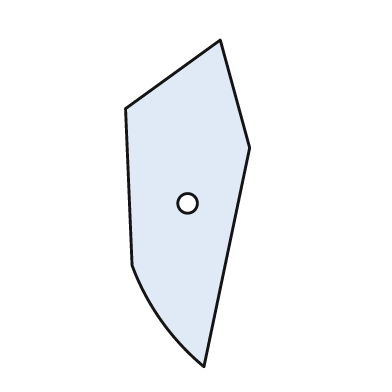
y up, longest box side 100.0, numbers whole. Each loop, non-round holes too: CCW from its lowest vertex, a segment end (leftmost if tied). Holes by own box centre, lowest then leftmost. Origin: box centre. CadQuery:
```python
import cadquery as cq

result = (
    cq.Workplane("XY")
    .moveTo(5.0, -50.0)
    .lineTo(19.0, 17.0)
    .lineTo(10.0, 50.0)
    .lineTo(-19.0, 29.0)
    .lineTo(-17.0, -19.0)
    .threePointArc((-8.0, -36.0), (5.0, -50.0))
    .close()
    .moveTo(0.0, 0.0)
    .circle(3.0)
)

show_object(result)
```